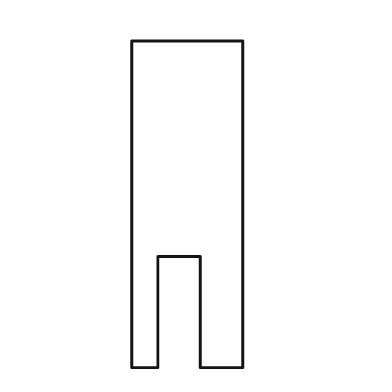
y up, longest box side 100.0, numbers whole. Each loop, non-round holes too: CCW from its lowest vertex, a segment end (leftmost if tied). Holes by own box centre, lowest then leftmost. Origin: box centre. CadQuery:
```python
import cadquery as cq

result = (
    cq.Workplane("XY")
    .moveTo(-17.0, -50.0)
    .lineTo(-9.0, -50.0)
    .lineTo(-9.0, -16.0)
    .lineTo(4.0, -16.0)
    .lineTo(4.0, -50.0)
    .lineTo(17.0, -50.0)
    .lineTo(17.0, 50.0)
    .lineTo(-17.0, 50.0)
    .close()
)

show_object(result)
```